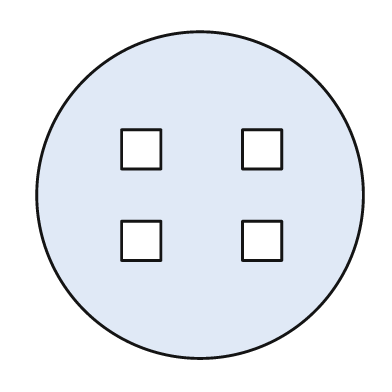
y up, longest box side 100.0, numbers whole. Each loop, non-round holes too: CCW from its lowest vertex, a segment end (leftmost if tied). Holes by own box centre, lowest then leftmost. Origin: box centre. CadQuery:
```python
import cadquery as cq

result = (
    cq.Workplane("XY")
    .moveTo(0.0, 0.0)
    .circle(50.0)
    .moveTo(-24.0, -20.0)
    .lineTo(-12.0, -20.0)
    .lineTo(-12.0, -8.0)
    .lineTo(-24.0, -8.0)
    .close()
    .moveTo(13.0, -20.0)
    .lineTo(25.0, -20.0)
    .lineTo(25.0, -8.0)
    .lineTo(13.0, -8.0)
    .close()
    .moveTo(-24.0, 8.0)
    .lineTo(-12.0, 8.0)
    .lineTo(-12.0, 20.0)
    .lineTo(-24.0, 20.0)
    .close()
    .moveTo(13.0, 8.0)
    .lineTo(25.0, 8.0)
    .lineTo(25.0, 20.0)
    .lineTo(13.0, 20.0)
    .close()
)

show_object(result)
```